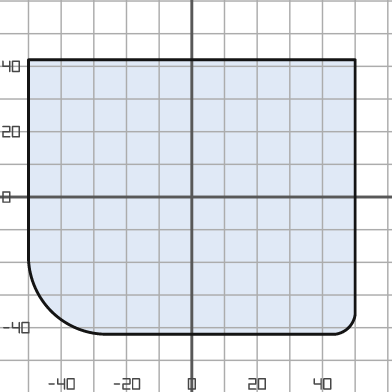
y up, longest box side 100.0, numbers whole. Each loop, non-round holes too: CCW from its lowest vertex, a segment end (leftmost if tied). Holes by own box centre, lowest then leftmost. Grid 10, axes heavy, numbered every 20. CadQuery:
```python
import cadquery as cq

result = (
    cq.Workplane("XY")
    .moveTo(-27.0, -42.0)
    .lineTo(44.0, -42.0)
    .threePointArc((48.0, -40.0), (50.0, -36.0))
    .lineTo(50.0, 42.0)
    .lineTo(-50.0, 42.0)
    .lineTo(-50.0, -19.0)
    .threePointArc((-43.0, -35.0), (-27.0, -42.0))
    .close()
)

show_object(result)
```